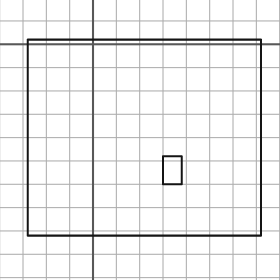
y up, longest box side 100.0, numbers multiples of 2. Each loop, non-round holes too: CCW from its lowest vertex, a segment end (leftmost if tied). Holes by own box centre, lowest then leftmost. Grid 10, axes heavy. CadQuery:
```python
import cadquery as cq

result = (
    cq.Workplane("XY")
    .moveTo(-28.0, -82.0)
    .lineTo(72.0, -82.0)
    .lineTo(72.0, 2.0)
    .lineTo(-28.0, 2.0)
    .close()
    .moveTo(30.0, -60.0)
    .lineTo(38.0, -60.0)
    .lineTo(38.0, -48.0)
    .lineTo(30.0, -48.0)
    .close()
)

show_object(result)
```